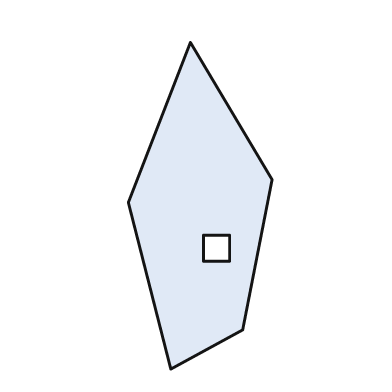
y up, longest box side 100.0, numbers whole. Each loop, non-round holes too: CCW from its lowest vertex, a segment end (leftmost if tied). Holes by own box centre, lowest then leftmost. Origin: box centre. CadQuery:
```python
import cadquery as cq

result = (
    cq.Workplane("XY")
    .moveTo(-9.0, -50.0)
    .lineTo(13.0, -38.0)
    .lineTo(22.0, 8.0)
    .lineTo(-3.0, 50.0)
    .lineTo(-22.0, 1.0)
    .close()
    .moveTo(1.0, -17.0)
    .lineTo(9.0, -17.0)
    .lineTo(9.0, -9.0)
    .lineTo(1.0, -9.0)
    .close()
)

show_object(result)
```